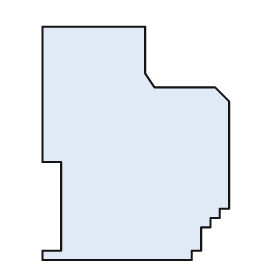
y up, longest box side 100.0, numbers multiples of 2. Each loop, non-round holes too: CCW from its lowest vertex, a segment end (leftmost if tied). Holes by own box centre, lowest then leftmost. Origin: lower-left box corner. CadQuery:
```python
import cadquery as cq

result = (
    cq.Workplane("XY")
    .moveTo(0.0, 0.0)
    .lineTo(64.0, 0.0)
    .lineTo(64.0, 4.0)
    .lineTo(68.0, 4.0)
    .lineTo(68.0, 14.0)
    .lineTo(72.0, 14.0)
    .lineTo(72.0, 18.0)
    .lineTo(76.0, 18.0)
    .lineTo(76.0, 22.0)
    .lineTo(80.0, 22.0)
    .lineTo(80.0, 68.0)
    .lineTo(74.0, 74.0)
    .lineTo(48.0, 74.0)
    .lineTo(44.0, 80.0)
    .lineTo(44.0, 100.0)
    .lineTo(0.0, 100.0)
    .lineTo(0.0, 42.0)
    .lineTo(8.0, 42.0)
    .lineTo(8.0, 4.0)
    .lineTo(0.0, 4.0)
    .close()
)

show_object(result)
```